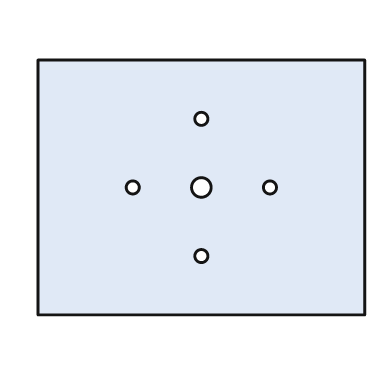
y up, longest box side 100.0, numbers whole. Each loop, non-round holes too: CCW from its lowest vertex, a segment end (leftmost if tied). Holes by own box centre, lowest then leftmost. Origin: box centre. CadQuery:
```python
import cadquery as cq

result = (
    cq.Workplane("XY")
    .moveTo(-50.0, -39.0)
    .lineTo(50.0, -39.0)
    .lineTo(50.0, 39.0)
    .lineTo(-50.0, 39.0)
    .close()
    .moveTo(0.0, -21.0)
    .circle(2.0)
    .moveTo(-21.0, 0.0)
    .circle(2.0)
    .moveTo(0.0, 0.0)
    .circle(3.0)
    .moveTo(21.0, 0.0)
    .circle(2.0)
    .moveTo(0.0, 21.0)
    .circle(2.0)
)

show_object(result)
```